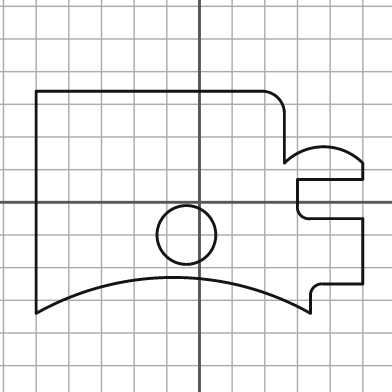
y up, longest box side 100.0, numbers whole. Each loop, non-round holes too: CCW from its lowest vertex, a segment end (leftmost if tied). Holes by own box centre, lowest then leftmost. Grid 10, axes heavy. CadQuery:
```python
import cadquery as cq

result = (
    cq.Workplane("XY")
    .moveTo(-50.0, -34.0)
    .threePointArc((-8.0, -23.0), (34.0, -34.0))
    .lineTo(34.0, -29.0)
    .threePointArc((35.0, -26.0), (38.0, -25.0))
    .lineTo(50.0, -25.0)
    .lineTo(50.0, -5.0)
    .lineTo(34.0, -5.0)
    .threePointArc((31.0, -4.0), (30.0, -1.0))
    .lineTo(30.0, 7.0)
    .lineTo(50.0, 7.0)
    .lineTo(50.0, 12.0)
    .threePointArc((38.0, 17.0), (26.0, 12.0))
    .lineTo(26.0, 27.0)
    .threePointArc((24.0, 32.0), (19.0, 34.0))
    .lineTo(-50.0, 34.0)
    .close()
    .moveTo(-4.0, -10.0)
    .circle(9.0)
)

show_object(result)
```